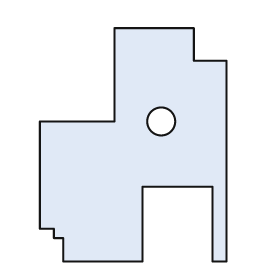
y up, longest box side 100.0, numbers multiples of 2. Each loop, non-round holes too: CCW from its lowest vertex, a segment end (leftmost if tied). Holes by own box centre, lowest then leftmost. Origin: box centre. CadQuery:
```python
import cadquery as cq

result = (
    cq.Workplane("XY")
    .moveTo(-30.0, -50.0)
    .lineTo(4.0, -50.0)
    .lineTo(4.0, -18.0)
    .lineTo(34.0, -18.0)
    .lineTo(34.0, -50.0)
    .lineTo(40.0, -50.0)
    .lineTo(40.0, 36.0)
    .lineTo(26.0, 36.0)
    .lineTo(26.0, 50.0)
    .lineTo(-8.0, 50.0)
    .lineTo(-8.0, 10.0)
    .lineTo(-40.0, 10.0)
    .lineTo(-40.0, -36.0)
    .lineTo(-34.0, -36.0)
    .lineTo(-34.0, -40.0)
    .lineTo(-30.0, -40.0)
    .close()
    .moveTo(12.0, 10.0)
    .circle(6.0)
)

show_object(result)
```